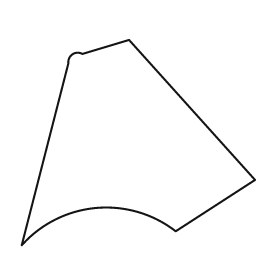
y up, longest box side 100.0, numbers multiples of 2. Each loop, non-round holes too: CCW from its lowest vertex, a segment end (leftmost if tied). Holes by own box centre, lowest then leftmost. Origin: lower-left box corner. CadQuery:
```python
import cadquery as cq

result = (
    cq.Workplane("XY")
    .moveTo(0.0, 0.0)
    .threePointArc((32.0, 16.0), (66.0, 6.0))
    .lineTo(100.0, 28.0)
    .lineTo(46.0, 88.0)
    .lineTo(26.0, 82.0)
    .threePointArc((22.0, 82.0), (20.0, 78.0))
    .close()
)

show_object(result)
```